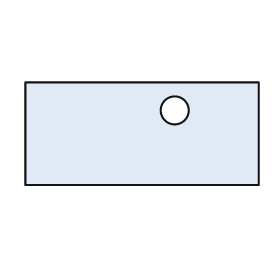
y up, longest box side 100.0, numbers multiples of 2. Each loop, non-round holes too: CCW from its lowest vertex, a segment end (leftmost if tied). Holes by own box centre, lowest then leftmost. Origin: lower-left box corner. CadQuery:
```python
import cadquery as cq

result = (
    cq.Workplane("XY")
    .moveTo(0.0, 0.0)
    .lineTo(100.0, 0.0)
    .lineTo(100.0, 44.0)
    .lineTo(0.0, 44.0)
    .close()
    .moveTo(64.0, 32.0)
    .circle(6.0)
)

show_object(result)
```